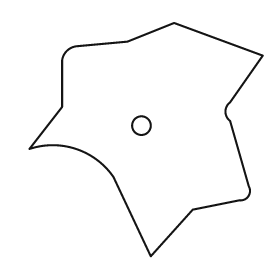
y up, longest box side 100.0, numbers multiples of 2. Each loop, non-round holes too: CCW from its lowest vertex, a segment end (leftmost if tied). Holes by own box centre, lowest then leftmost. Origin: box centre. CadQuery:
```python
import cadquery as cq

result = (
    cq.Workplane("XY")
    .moveTo(2.0, -50.0)
    .lineTo(20.0, -30.0)
    .lineTo(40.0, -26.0)
    .threePointArc((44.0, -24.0), (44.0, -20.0))
    .lineTo(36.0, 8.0)
    .threePointArc((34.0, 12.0), (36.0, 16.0))
    .lineTo(50.0, 36.0)
    .lineTo(12.0, 50.0)
    .lineTo(-8.0, 42.0)
    .lineTo(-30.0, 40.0)
    .threePointArc((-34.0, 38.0), (-36.0, 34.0))
    .lineTo(-36.0, 14.0)
    .lineTo(-50.0, -4.0)
    .threePointArc((-30.0, -4.0), (-14.0, -16.0))
    .close()
    .moveTo(-2.0, 6.0)
    .circle(4.0)
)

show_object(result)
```